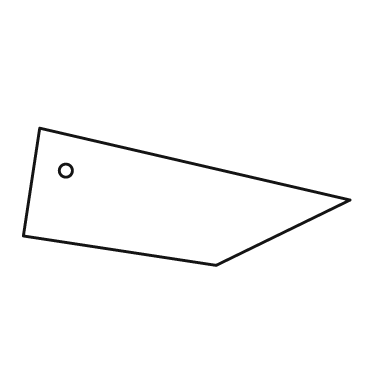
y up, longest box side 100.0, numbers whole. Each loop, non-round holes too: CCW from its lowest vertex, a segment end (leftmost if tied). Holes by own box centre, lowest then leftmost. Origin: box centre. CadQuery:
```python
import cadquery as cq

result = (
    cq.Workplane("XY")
    .moveTo(9.0, -21.0)
    .lineTo(50.0, -1.0)
    .lineTo(-45.0, 21.0)
    .lineTo(-50.0, -12.0)
    .close()
    .moveTo(-37.0, 8.0)
    .circle(2.0)
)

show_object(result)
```